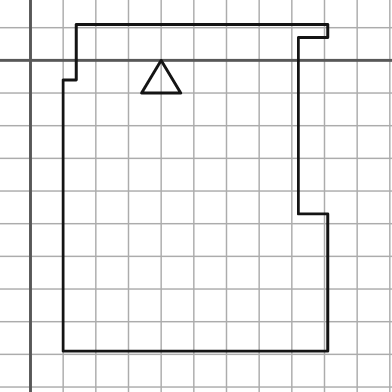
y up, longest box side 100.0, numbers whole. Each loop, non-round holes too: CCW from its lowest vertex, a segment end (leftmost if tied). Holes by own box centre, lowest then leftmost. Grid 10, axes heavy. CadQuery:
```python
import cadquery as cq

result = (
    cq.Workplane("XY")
    .moveTo(10.0, -89.0)
    .lineTo(91.0, -89.0)
    .lineTo(91.0, -47.0)
    .lineTo(82.0, -47.0)
    .lineTo(82.0, 7.0)
    .lineTo(91.0, 7.0)
    .lineTo(91.0, 11.0)
    .lineTo(14.0, 11.0)
    .lineTo(14.0, -6.0)
    .lineTo(10.0, -6.0)
    .close()
    .moveTo(34.0, -10.0)
    .lineTo(46.0, -10.0)
    .lineTo(40.0, 0.0)
    .close()
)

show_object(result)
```